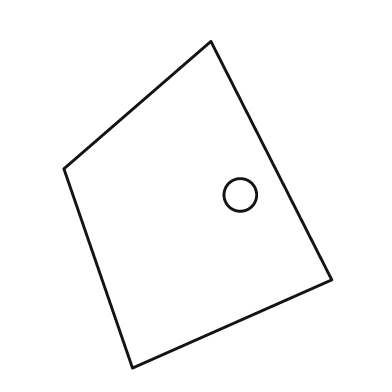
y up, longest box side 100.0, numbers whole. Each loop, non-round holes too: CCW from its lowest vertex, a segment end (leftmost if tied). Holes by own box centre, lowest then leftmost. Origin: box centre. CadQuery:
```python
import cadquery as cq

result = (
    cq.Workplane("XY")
    .moveTo(-20.0, -50.0)
    .lineTo(41.0, -23.0)
    .lineTo(4.0, 50.0)
    .lineTo(-41.0, 11.0)
    .close()
    .moveTo(13.0, 3.0)
    .circle(5.0)
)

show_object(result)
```